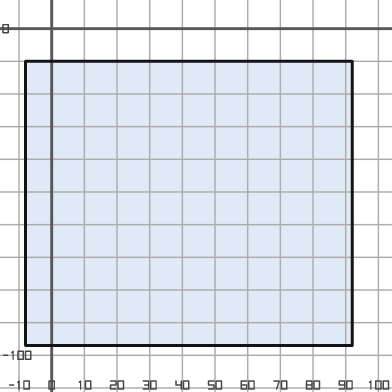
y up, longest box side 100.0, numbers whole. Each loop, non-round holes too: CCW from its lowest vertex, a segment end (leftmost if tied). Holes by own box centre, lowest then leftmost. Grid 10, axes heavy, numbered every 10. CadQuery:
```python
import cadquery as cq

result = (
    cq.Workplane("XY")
    .moveTo(-8.0, -97.0)
    .lineTo(92.0, -97.0)
    .lineTo(92.0, -10.0)
    .lineTo(-8.0, -10.0)
    .close()
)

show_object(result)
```